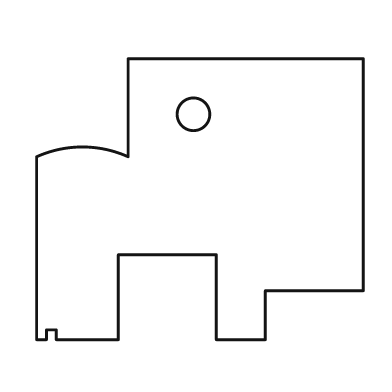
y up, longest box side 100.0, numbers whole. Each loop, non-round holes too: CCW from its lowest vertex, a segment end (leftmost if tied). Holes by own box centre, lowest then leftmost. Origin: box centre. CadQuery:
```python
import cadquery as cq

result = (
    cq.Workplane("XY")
    .moveTo(-50.0, -43.0)
    .lineTo(-47.0, -43.0)
    .lineTo(-47.0, -40.0)
    .lineTo(-44.0, -40.0)
    .lineTo(-44.0, -43.0)
    .lineTo(-25.0, -43.0)
    .lineTo(-25.0, -17.0)
    .lineTo(5.0, -17.0)
    .lineTo(5.0, -43.0)
    .lineTo(20.0, -43.0)
    .lineTo(20.0, -28.0)
    .lineTo(50.0, -28.0)
    .lineTo(50.0, 43.0)
    .lineTo(-22.0, 43.0)
    .lineTo(-22.0, 13.0)
    .threePointArc((-36.0, 16.0), (-50.0, 13.0))
    .close()
    .moveTo(-2.0, 26.0)
    .circle(5.0)
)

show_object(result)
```